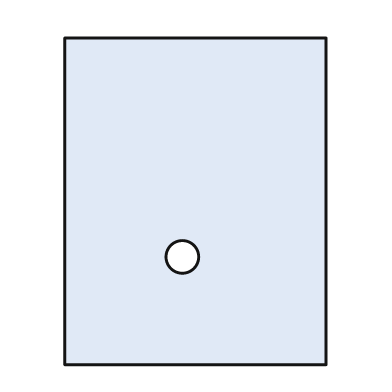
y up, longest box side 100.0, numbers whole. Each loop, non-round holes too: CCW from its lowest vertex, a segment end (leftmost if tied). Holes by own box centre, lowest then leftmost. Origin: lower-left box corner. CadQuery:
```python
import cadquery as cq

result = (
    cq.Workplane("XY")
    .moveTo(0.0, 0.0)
    .lineTo(80.0, 0.0)
    .lineTo(80.0, 100.0)
    .lineTo(0.0, 100.0)
    .close()
    .moveTo(36.0, 33.0)
    .circle(5.0)
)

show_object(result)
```